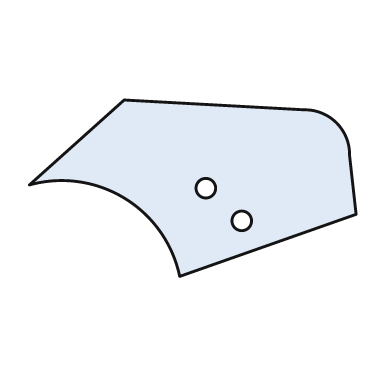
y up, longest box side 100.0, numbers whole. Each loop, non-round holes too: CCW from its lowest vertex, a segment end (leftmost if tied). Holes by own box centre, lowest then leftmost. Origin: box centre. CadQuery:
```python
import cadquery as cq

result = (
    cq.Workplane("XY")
    .moveTo(-4.0, -27.0)
    .lineTo(50.0, -8.0)
    .lineTo(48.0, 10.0)
    .threePointArc((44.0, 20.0), (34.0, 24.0))
    .lineTo(-21.0, 27.0)
    .lineTo(-50.0, 1.0)
    .threePointArc((-21.0, -3.0), (-4.0, -27.0))
    .close()
    .moveTo(15.0, -10.0)
    .circle(3.0)
    .moveTo(4.0, 0.0)
    .circle(3.0)
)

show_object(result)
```